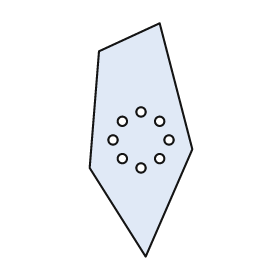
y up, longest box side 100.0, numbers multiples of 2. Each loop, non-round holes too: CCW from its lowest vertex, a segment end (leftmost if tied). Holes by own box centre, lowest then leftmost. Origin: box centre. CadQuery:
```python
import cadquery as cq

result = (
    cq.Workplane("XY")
    .moveTo(2.0, -50.0)
    .lineTo(22.0, -4.0)
    .lineTo(8.0, 50.0)
    .lineTo(-18.0, 38.0)
    .lineTo(-22.0, -12.0)
    .close()
    .moveTo(0.0, -12.0)
    .circle(2.0)
    .moveTo(-8.0, -8.0)
    .circle(2.0)
    .moveTo(8.0, -8.0)
    .circle(2.0)
    .moveTo(-12.0, 0.0)
    .circle(2.0)
    .moveTo(12.0, 0.0)
    .circle(2.0)
    .moveTo(-8.0, 8.0)
    .circle(2.0)
    .moveTo(8.0, 8.0)
    .circle(2.0)
    .moveTo(0.0, 12.0)
    .circle(2.0)
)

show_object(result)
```